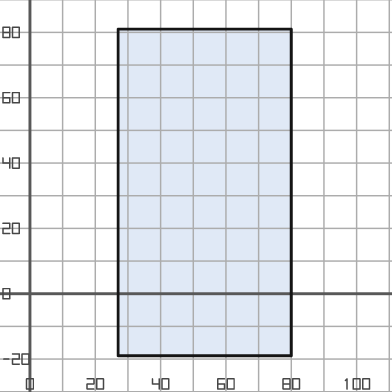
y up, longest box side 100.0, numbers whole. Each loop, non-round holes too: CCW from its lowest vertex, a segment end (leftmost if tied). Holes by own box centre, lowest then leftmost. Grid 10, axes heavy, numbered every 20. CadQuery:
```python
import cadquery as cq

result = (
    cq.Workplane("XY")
    .moveTo(27.0, -19.0)
    .lineTo(80.0, -19.0)
    .lineTo(80.0, 81.0)
    .lineTo(27.0, 81.0)
    .close()
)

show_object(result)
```